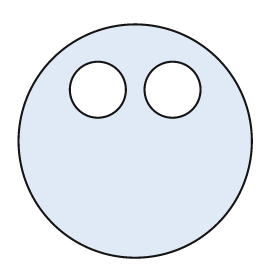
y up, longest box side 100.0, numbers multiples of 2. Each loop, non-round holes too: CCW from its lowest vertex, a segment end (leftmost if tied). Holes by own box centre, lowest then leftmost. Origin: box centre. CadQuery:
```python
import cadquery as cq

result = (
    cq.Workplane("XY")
    .moveTo(0.0, 0.0)
    .circle(50.0)
    .moveTo(-16.0, 22.0)
    .circle(12.0)
    .moveTo(16.0, 22.0)
    .circle(12.0)
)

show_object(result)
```